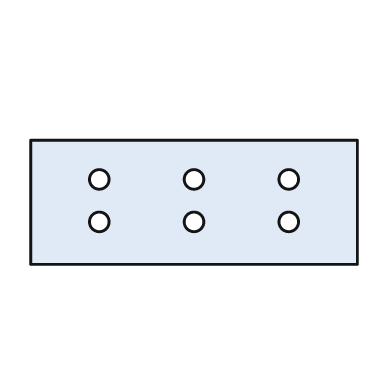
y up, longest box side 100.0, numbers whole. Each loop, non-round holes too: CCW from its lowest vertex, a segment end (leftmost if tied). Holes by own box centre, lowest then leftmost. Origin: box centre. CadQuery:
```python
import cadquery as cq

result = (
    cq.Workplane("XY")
    .moveTo(-50.0, -19.0)
    .lineTo(50.0, -19.0)
    .lineTo(50.0, 19.0)
    .lineTo(-50.0, 19.0)
    .close()
    .moveTo(-29.0, -6.0)
    .circle(3.0)
    .moveTo(0.0, -6.0)
    .circle(3.0)
    .moveTo(29.0, -6.0)
    .circle(3.0)
    .moveTo(-29.0, 7.0)
    .circle(3.0)
    .moveTo(0.0, 7.0)
    .circle(3.0)
    .moveTo(29.0, 7.0)
    .circle(3.0)
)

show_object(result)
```